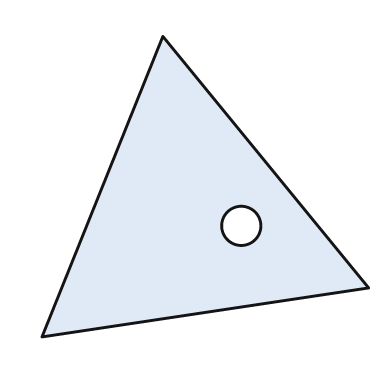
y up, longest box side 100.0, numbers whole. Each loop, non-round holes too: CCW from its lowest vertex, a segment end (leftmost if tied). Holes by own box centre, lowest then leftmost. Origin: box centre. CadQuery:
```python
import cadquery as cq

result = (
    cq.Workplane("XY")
    .moveTo(-50.0, -46.0)
    .lineTo(50.0, -31.0)
    .lineTo(-13.0, 46.0)
    .close()
    .moveTo(11.0, -12.0)
    .circle(6.0)
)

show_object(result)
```